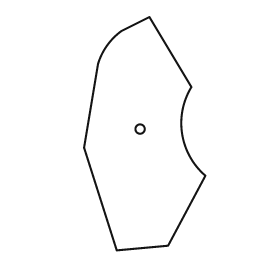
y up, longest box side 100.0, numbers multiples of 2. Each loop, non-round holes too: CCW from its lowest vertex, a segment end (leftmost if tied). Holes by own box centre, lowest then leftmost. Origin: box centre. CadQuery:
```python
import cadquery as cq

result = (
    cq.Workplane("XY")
    .moveTo(-12.0, -50.0)
    .lineTo(10.0, -48.0)
    .lineTo(26.0, -18.0)
    .threePointArc((16.0, 0.0), (20.0, 20.0))
    .lineTo(2.0, 50.0)
    .lineTo(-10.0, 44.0)
    .threePointArc((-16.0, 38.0), (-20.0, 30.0))
    .lineTo(-26.0, -6.0)
    .close()
    .moveTo(-2.0, 2.0)
    .circle(2.0)
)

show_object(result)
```